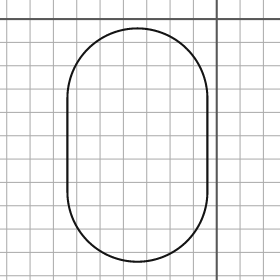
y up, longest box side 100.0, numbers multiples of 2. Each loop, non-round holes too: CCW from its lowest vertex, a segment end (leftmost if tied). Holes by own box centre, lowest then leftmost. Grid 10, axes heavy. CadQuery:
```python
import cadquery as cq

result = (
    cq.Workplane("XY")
    .moveTo(-64.0, -74.0)
    .threePointArc((-34.0, -104.0), (-4.0, -74.0))
    .lineTo(-4.0, -34.0)
    .threePointArc((-34.0, -4.0), (-64.0, -34.0))
    .close()
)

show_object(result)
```